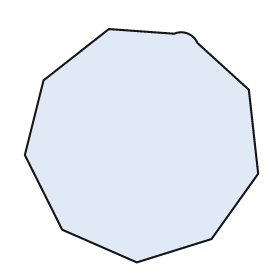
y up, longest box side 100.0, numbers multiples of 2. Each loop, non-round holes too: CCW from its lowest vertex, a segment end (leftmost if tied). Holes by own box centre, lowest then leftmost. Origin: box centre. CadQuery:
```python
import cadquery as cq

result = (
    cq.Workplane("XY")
    .moveTo(-2.0, -50.0)
    .lineTo(30.0, -40.0)
    .lineTo(50.0, -12.0)
    .lineTo(46.0, 24.0)
    .lineTo(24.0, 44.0)
    .threePointArc((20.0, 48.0), (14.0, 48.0))
    .lineTo(-14.0, 50.0)
    .lineTo(-42.0, 28.0)
    .lineTo(-50.0, -4.0)
    .lineTo(-34.0, -36.0)
    .close()
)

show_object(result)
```